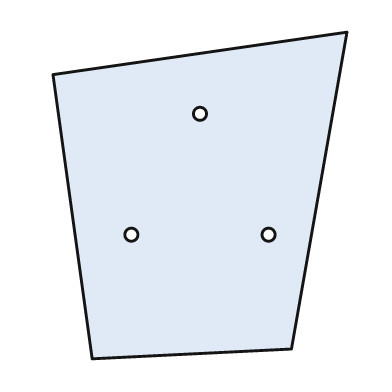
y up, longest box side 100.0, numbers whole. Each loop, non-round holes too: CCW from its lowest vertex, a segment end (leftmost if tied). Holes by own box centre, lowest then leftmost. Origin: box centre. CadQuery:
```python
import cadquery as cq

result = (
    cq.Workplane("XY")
    .moveTo(-33.0, -50.0)
    .lineTo(28.0, -47.0)
    .lineTo(45.0, 50.0)
    .lineTo(-45.0, 37.0)
    .close()
    .moveTo(-21.0, -12.0)
    .circle(2.0)
    .moveTo(21.0, -12.0)
    .circle(2.0)
    .moveTo(0.0, 25.0)
    .circle(2.0)
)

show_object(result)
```